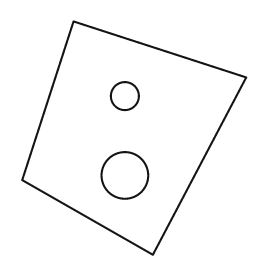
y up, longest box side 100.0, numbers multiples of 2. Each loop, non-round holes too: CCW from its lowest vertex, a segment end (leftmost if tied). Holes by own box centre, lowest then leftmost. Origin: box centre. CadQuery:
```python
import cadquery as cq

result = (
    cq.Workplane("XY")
    .moveTo(8.0, -50.0)
    .lineTo(48.0, 26.0)
    .lineTo(-26.0, 50.0)
    .lineTo(-48.0, -18.0)
    .close()
    .moveTo(-4.0, -16.0)
    .circle(10.0)
    .moveTo(-4.0, 18.0)
    .circle(6.0)
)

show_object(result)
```